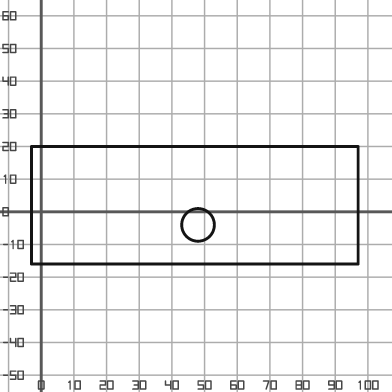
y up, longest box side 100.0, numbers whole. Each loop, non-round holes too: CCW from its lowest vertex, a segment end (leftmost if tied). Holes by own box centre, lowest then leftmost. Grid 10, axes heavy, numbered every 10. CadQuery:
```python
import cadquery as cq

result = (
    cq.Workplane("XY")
    .moveTo(-3.0, -16.0)
    .lineTo(97.0, -16.0)
    .lineTo(97.0, 20.0)
    .lineTo(-3.0, 20.0)
    .close()
    .moveTo(48.0, -4.0)
    .circle(5.0)
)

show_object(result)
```